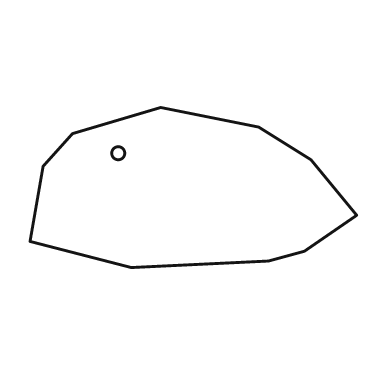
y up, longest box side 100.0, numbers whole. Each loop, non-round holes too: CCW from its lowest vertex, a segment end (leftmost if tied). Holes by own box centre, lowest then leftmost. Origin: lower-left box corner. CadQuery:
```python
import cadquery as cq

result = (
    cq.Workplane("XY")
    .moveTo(31.0, 0.0)
    .lineTo(73.0, 2.0)
    .lineTo(84.0, 5.0)
    .lineTo(100.0, 16.0)
    .lineTo(86.0, 33.0)
    .lineTo(70.0, 43.0)
    .lineTo(40.0, 49.0)
    .lineTo(13.0, 41.0)
    .lineTo(4.0, 31.0)
    .lineTo(0.0, 8.0)
    .close()
    .moveTo(27.0, 35.0)
    .circle(2.0)
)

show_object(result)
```